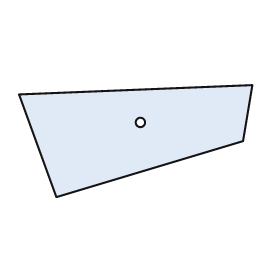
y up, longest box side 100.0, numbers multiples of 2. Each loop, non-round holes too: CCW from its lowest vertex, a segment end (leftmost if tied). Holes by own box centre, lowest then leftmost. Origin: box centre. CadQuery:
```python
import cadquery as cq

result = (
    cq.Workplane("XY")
    .moveTo(-34.0, -24.0)
    .lineTo(46.0, 0.0)
    .lineTo(50.0, 24.0)
    .lineTo(-50.0, 20.0)
    .close()
    .moveTo(2.0, 8.0)
    .circle(2.0)
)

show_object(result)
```